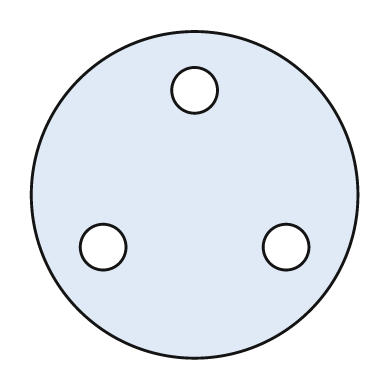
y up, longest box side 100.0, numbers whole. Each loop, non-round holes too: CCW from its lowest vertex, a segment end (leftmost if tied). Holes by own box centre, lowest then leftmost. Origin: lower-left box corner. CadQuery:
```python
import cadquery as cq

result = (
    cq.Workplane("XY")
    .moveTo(50.0, 50.0)
    .circle(50.0)
    .moveTo(22.0, 34.0)
    .circle(7.0)
    .moveTo(78.0, 34.0)
    .circle(7.0)
    .moveTo(50.0, 82.0)
    .circle(7.0)
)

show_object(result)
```